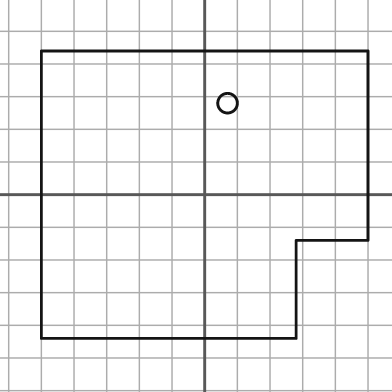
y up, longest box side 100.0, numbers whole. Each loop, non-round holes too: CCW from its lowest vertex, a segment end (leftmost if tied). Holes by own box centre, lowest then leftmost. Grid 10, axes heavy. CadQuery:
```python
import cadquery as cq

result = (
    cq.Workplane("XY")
    .moveTo(-50.0, -44.0)
    .lineTo(28.0, -44.0)
    .lineTo(28.0, -14.0)
    .lineTo(50.0, -14.0)
    .lineTo(50.0, 44.0)
    .lineTo(-50.0, 44.0)
    .close()
    .moveTo(7.0, 28.0)
    .circle(3.0)
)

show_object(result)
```